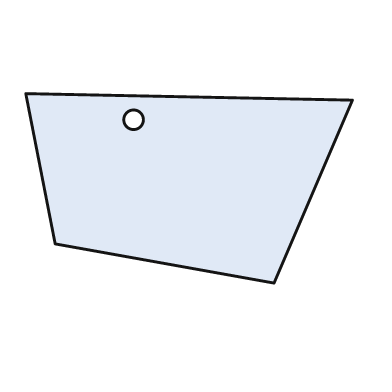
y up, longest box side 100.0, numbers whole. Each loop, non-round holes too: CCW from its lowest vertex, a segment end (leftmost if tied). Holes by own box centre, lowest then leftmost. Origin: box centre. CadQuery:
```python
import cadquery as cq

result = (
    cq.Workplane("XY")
    .moveTo(26.0, -29.0)
    .lineTo(50.0, 27.0)
    .lineTo(-50.0, 29.0)
    .lineTo(-41.0, -17.0)
    .close()
    .moveTo(-17.0, 21.0)
    .circle(3.0)
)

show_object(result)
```